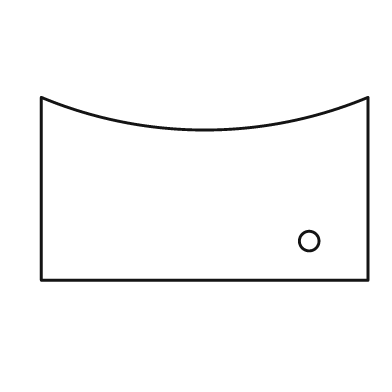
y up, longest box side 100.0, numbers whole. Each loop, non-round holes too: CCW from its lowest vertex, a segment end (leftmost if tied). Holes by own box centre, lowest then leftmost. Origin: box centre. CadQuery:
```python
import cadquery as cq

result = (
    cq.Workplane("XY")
    .moveTo(-50.0, -28.0)
    .lineTo(50.0, -28.0)
    .lineTo(50.0, 28.0)
    .threePointArc((0.0, 18.0), (-50.0, 28.0))
    .close()
    .moveTo(32.0, -16.0)
    .circle(3.0)
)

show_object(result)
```